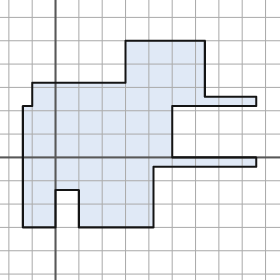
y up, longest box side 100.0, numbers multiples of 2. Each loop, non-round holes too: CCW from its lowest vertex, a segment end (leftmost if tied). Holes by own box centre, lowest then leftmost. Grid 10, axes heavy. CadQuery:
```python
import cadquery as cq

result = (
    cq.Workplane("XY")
    .moveTo(-14.0, -30.0)
    .lineTo(0.0, -30.0)
    .lineTo(0.0, -14.0)
    .lineTo(10.0, -14.0)
    .lineTo(10.0, -30.0)
    .lineTo(42.0, -30.0)
    .lineTo(42.0, -4.0)
    .lineTo(86.0, -4.0)
    .lineTo(86.0, 0.0)
    .lineTo(50.0, 0.0)
    .lineTo(50.0, 22.0)
    .lineTo(86.0, 22.0)
    .lineTo(86.0, 26.0)
    .lineTo(64.0, 26.0)
    .lineTo(64.0, 50.0)
    .lineTo(30.0, 50.0)
    .lineTo(30.0, 32.0)
    .lineTo(-10.0, 32.0)
    .lineTo(-10.0, 22.0)
    .lineTo(-14.0, 22.0)
    .close()
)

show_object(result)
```